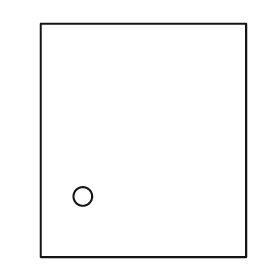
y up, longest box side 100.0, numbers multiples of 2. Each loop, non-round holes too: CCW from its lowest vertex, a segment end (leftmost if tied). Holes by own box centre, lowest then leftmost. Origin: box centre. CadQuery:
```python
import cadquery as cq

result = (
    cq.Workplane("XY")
    .moveTo(-44.0, -50.0)
    .lineTo(44.0, -50.0)
    .lineTo(44.0, 50.0)
    .lineTo(-44.0, 50.0)
    .close()
    .moveTo(-26.0, -24.0)
    .circle(4.0)
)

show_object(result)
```